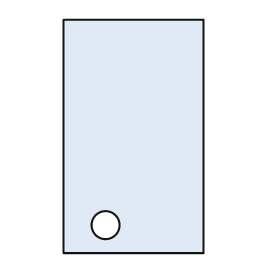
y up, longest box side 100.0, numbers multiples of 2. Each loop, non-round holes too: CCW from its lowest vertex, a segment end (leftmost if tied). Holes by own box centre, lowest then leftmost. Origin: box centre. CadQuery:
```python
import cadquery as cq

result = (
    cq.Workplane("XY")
    .moveTo(-30.0, -50.0)
    .lineTo(30.0, -50.0)
    .lineTo(30.0, 50.0)
    .lineTo(-30.0, 50.0)
    .close()
    .moveTo(-12.0, -38.0)
    .circle(6.0)
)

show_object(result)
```